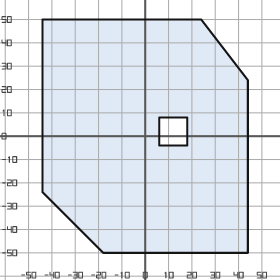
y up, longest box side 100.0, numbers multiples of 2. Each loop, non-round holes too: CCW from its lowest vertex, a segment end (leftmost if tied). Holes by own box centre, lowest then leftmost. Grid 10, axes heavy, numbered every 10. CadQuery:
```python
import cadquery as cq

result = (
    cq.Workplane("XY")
    .moveTo(-18.0, -50.0)
    .lineTo(44.0, -50.0)
    .lineTo(44.0, 24.0)
    .lineTo(24.0, 50.0)
    .lineTo(-44.0, 50.0)
    .lineTo(-44.0, -24.0)
    .close()
    .moveTo(6.0, -4.0)
    .lineTo(18.0, -4.0)
    .lineTo(18.0, 8.0)
    .lineTo(6.0, 8.0)
    .close()
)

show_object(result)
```